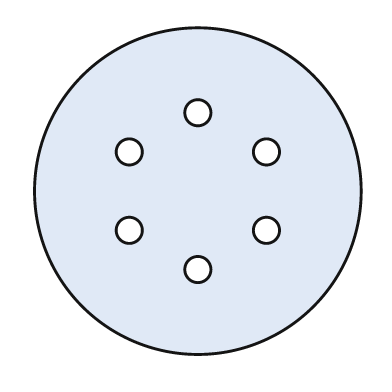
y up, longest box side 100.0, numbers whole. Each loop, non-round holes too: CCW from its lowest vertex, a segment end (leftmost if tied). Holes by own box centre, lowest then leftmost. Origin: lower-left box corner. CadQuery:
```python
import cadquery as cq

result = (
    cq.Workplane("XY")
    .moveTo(50.0, 50.0)
    .circle(50.0)
    .moveTo(50.0, 26.0)
    .circle(4.0)
    .moveTo(29.0, 38.0)
    .circle(4.0)
    .moveTo(71.0, 38.0)
    .circle(4.0)
    .moveTo(29.0, 62.0)
    .circle(4.0)
    .moveTo(71.0, 62.0)
    .circle(4.0)
    .moveTo(50.0, 74.0)
    .circle(4.0)
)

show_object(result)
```